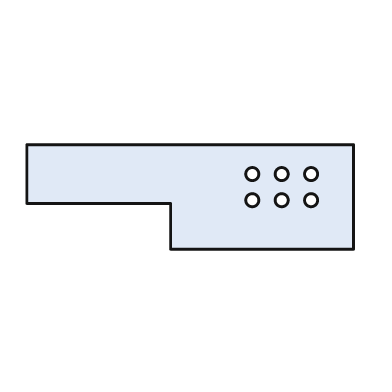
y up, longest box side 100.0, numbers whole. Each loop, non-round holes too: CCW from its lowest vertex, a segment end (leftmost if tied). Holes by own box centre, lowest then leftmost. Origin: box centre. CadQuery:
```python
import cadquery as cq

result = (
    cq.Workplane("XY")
    .moveTo(-6.0, -16.0)
    .lineTo(50.0, -16.0)
    .lineTo(50.0, 16.0)
    .lineTo(-50.0, 16.0)
    .lineTo(-50.0, -2.0)
    .lineTo(-6.0, -2.0)
    .close()
    .moveTo(19.0, -1.0)
    .circle(2.0)
    .moveTo(28.0, -1.0)
    .circle(2.0)
    .moveTo(37.0, -1.0)
    .circle(2.0)
    .moveTo(19.0, 7.0)
    .circle(2.0)
    .moveTo(28.0, 7.0)
    .circle(2.0)
    .moveTo(37.0, 7.0)
    .circle(2.0)
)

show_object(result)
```